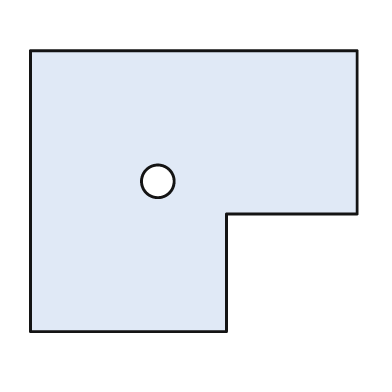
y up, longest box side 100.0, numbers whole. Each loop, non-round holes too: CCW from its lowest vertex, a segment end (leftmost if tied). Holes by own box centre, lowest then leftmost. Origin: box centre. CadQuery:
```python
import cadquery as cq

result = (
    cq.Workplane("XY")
    .moveTo(-50.0, -43.0)
    .lineTo(10.0, -43.0)
    .lineTo(10.0, -7.0)
    .lineTo(50.0, -7.0)
    .lineTo(50.0, 43.0)
    .lineTo(-50.0, 43.0)
    .close()
    .moveTo(-11.0, 3.0)
    .circle(5.0)
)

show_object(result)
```